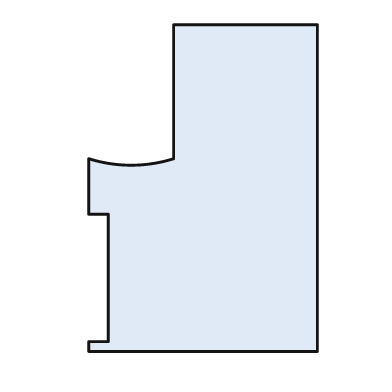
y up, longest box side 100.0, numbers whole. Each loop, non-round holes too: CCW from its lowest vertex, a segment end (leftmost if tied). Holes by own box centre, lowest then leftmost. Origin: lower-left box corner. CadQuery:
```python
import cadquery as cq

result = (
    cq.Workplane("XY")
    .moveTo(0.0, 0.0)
    .lineTo(70.0, 0.0)
    .lineTo(70.0, 100.0)
    .lineTo(26.0, 100.0)
    .lineTo(26.0, 59.0)
    .threePointArc((13.0, 57.0), (0.0, 59.0))
    .lineTo(0.0, 42.0)
    .lineTo(6.0, 42.0)
    .lineTo(6.0, 3.0)
    .lineTo(0.0, 3.0)
    .close()
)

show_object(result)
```